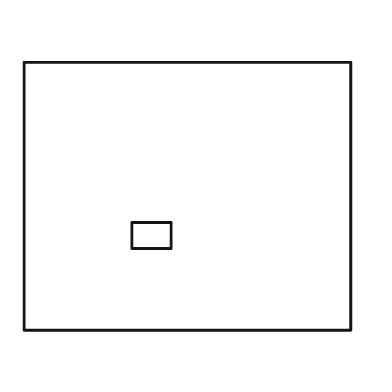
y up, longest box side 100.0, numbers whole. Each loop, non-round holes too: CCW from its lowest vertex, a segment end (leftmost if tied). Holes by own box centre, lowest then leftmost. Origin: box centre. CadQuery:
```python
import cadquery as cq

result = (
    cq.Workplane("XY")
    .moveTo(-50.0, -41.0)
    .lineTo(50.0, -41.0)
    .lineTo(50.0, 41.0)
    .lineTo(-50.0, 41.0)
    .close()
    .moveTo(-17.0, -16.0)
    .lineTo(-5.0, -16.0)
    .lineTo(-5.0, -8.0)
    .lineTo(-17.0, -8.0)
    .close()
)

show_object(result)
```